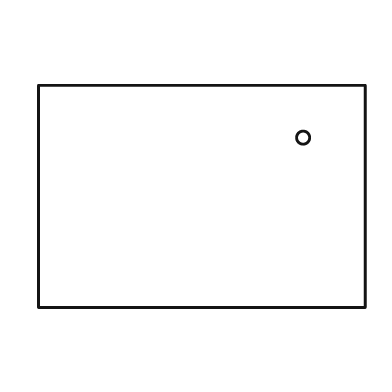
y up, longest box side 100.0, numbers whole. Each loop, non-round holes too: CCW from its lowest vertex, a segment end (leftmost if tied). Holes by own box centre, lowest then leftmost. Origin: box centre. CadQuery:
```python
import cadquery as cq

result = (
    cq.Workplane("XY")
    .moveTo(-50.0, -34.0)
    .lineTo(50.0, -34.0)
    .lineTo(50.0, 34.0)
    .lineTo(-50.0, 34.0)
    .close()
    .moveTo(31.0, 18.0)
    .circle(2.0)
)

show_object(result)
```